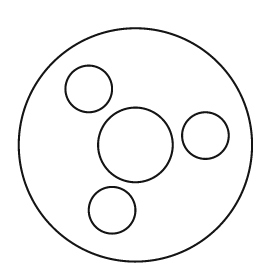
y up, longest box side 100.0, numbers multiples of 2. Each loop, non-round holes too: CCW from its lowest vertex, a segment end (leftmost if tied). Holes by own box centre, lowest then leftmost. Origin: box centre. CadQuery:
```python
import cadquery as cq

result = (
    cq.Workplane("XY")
    .moveTo(0.0, 0.0)
    .circle(50.0)
    .moveTo(-10.0, -28.0)
    .circle(10.0)
    .moveTo(0.0, 0.0)
    .circle(16.0)
    .moveTo(30.0, 4.0)
    .circle(10.0)
    .moveTo(-20.0, 24.0)
    .circle(10.0)
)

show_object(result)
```